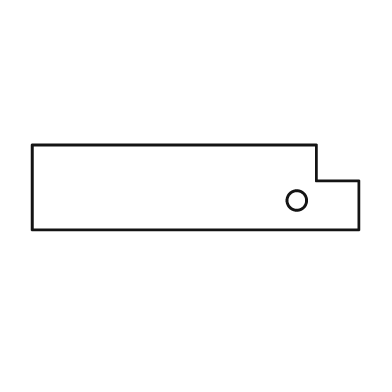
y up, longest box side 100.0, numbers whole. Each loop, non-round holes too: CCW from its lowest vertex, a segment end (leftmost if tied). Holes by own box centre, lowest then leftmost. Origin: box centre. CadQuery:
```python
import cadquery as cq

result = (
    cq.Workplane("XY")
    .moveTo(-50.0, -13.0)
    .lineTo(50.0, -13.0)
    .lineTo(50.0, 2.0)
    .lineTo(37.0, 2.0)
    .lineTo(37.0, 13.0)
    .lineTo(-50.0, 13.0)
    .close()
    .moveTo(31.0, -4.0)
    .circle(3.0)
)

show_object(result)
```